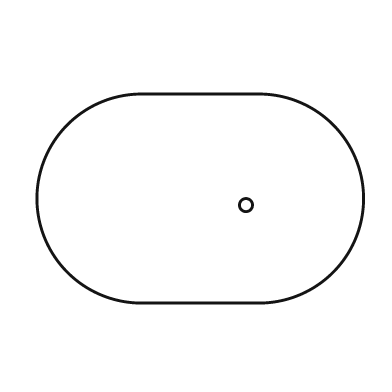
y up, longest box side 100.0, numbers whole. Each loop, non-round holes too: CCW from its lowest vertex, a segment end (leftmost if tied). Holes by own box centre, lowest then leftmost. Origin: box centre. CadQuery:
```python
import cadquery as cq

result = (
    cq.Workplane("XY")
    .moveTo(-18.0, -32.0)
    .lineTo(18.0, -32.0)
    .threePointArc((50.0, 0.0), (18.0, 32.0))
    .lineTo(-18.0, 32.0)
    .threePointArc((-50.0, 0.0), (-18.0, -32.0))
    .close()
    .moveTo(14.0, -2.0)
    .circle(2.0)
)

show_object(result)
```